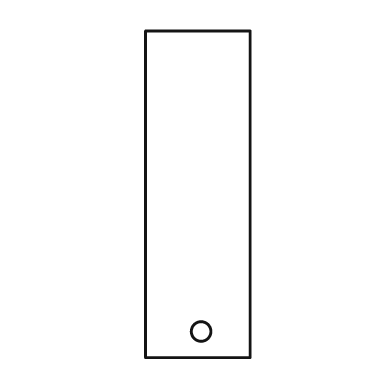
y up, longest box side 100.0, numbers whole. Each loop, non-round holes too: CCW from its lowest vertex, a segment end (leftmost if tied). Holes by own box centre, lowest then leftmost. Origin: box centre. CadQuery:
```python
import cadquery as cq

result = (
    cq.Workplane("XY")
    .moveTo(-16.0, -50.0)
    .lineTo(16.0, -50.0)
    .lineTo(16.0, 50.0)
    .lineTo(-16.0, 50.0)
    .close()
    .moveTo(1.0, -42.0)
    .circle(3.0)
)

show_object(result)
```